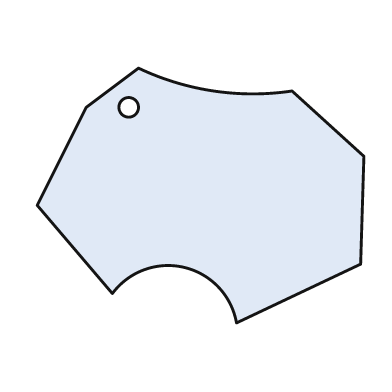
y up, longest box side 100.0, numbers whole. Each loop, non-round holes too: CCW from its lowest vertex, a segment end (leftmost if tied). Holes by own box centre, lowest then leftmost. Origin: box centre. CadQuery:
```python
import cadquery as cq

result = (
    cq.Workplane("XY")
    .moveTo(11.0, -39.0)
    .lineTo(49.0, -21.0)
    .lineTo(50.0, 12.0)
    .lineTo(28.0, 32.0)
    .threePointArc((4.0, 32.0), (-19.0, 39.0))
    .lineTo(-35.0, 27.0)
    .lineTo(-50.0, -3.0)
    .lineTo(-27.0, -30.0)
    .threePointArc((-5.0, -22.0), (11.0, -39.0))
    .close()
    .moveTo(-22.0, 27.0)
    .circle(3.0)
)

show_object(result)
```